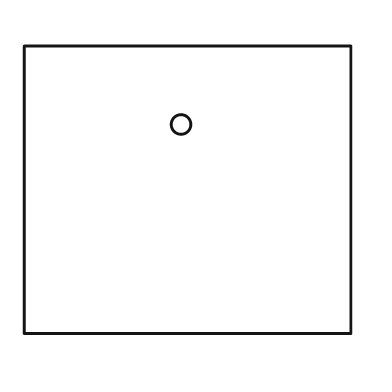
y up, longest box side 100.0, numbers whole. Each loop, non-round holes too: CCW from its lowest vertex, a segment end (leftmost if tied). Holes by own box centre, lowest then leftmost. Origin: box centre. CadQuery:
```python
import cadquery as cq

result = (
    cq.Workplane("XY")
    .moveTo(-50.0, -44.0)
    .lineTo(50.0, -44.0)
    .lineTo(50.0, 44.0)
    .lineTo(-50.0, 44.0)
    .close()
    .moveTo(-2.0, 20.0)
    .circle(3.0)
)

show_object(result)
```